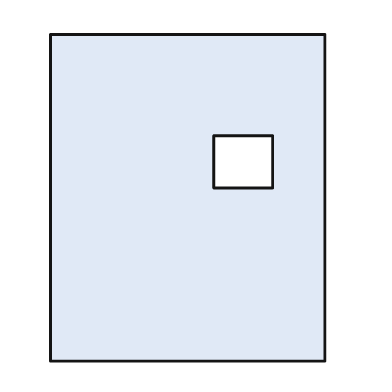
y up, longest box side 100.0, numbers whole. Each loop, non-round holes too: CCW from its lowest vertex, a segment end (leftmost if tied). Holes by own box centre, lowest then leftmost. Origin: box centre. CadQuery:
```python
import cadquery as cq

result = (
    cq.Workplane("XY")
    .moveTo(-42.0, -50.0)
    .lineTo(42.0, -50.0)
    .lineTo(42.0, 50.0)
    .lineTo(-42.0, 50.0)
    .close()
    .moveTo(8.0, 3.0)
    .lineTo(26.0, 3.0)
    .lineTo(26.0, 19.0)
    .lineTo(8.0, 19.0)
    .close()
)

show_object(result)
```